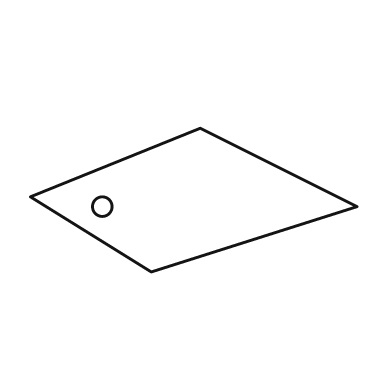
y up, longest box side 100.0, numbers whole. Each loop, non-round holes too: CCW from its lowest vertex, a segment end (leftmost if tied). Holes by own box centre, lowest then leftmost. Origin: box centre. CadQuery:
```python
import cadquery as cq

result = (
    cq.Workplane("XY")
    .moveTo(-13.0, -22.0)
    .lineTo(50.0, -2.0)
    .lineTo(2.0, 22.0)
    .lineTo(-50.0, 1.0)
    .close()
    .moveTo(-28.0, -2.0)
    .circle(3.0)
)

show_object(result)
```